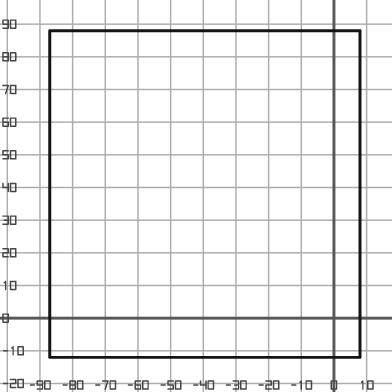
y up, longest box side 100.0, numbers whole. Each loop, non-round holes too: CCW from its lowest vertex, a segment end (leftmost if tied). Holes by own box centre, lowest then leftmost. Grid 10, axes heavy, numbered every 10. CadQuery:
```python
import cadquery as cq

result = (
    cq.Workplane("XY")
    .moveTo(-87.0, -12.0)
    .lineTo(8.0, -12.0)
    .lineTo(8.0, 88.0)
    .lineTo(-87.0, 88.0)
    .close()
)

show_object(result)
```